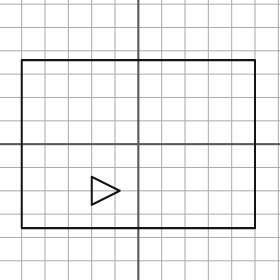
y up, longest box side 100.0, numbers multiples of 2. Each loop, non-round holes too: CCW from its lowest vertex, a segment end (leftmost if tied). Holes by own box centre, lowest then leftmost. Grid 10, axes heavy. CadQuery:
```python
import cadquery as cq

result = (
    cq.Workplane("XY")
    .moveTo(-50.0, -36.0)
    .lineTo(50.0, -36.0)
    .lineTo(50.0, 36.0)
    .lineTo(-50.0, 36.0)
    .close()
    .moveTo(-20.0, -26.0)
    .lineTo(-8.0, -20.0)
    .lineTo(-20.0, -14.0)
    .close()
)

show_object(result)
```